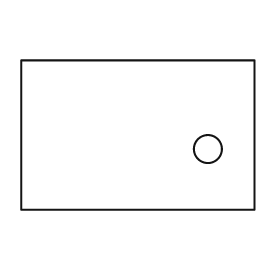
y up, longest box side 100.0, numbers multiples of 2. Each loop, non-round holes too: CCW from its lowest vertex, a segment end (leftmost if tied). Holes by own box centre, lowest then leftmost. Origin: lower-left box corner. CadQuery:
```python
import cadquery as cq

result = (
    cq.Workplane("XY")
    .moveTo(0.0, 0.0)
    .lineTo(100.0, 0.0)
    .lineTo(100.0, 64.0)
    .lineTo(0.0, 64.0)
    .close()
    .moveTo(80.0, 26.0)
    .circle(6.0)
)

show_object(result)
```